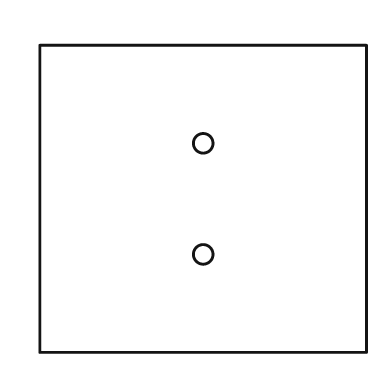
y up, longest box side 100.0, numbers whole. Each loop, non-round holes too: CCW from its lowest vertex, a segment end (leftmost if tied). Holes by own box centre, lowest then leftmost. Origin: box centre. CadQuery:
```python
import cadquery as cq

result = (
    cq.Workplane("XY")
    .moveTo(-50.0, -47.0)
    .lineTo(50.0, -47.0)
    .lineTo(50.0, 47.0)
    .lineTo(-50.0, 47.0)
    .close()
    .moveTo(0.0, -17.0)
    .circle(3.0)
    .moveTo(0.0, 17.0)
    .circle(3.0)
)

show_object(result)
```